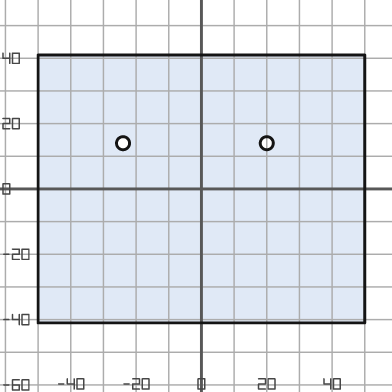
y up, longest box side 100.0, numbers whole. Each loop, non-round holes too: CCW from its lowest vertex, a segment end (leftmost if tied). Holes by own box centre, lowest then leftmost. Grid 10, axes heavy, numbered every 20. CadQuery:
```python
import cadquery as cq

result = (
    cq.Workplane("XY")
    .moveTo(-50.0, -41.0)
    .lineTo(50.0, -41.0)
    .lineTo(50.0, 41.0)
    .lineTo(-50.0, 41.0)
    .close()
    .moveTo(-24.0, 14.0)
    .circle(2.0)
    .moveTo(20.0, 14.0)
    .circle(2.0)
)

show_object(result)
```